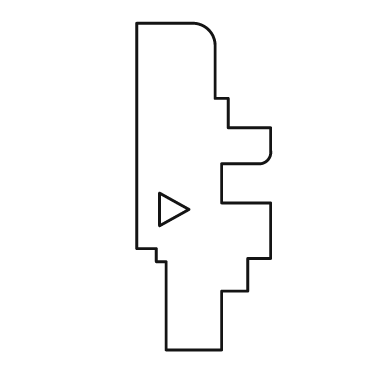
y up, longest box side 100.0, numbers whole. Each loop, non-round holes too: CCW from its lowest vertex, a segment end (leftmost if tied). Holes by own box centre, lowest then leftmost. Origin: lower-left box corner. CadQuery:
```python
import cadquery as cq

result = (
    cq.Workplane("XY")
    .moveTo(9.0, 0.0)
    .lineTo(26.0, 0.0)
    .lineTo(26.0, 18.0)
    .lineTo(34.0, 18.0)
    .lineTo(34.0, 28.0)
    .lineTo(41.0, 28.0)
    .lineTo(41.0, 45.0)
    .lineTo(26.0, 45.0)
    .lineTo(26.0, 57.0)
    .lineTo(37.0, 57.0)
    .threePointArc((40.0, 58.0), (41.0, 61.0))
    .lineTo(41.0, 68.0)
    .lineTo(28.0, 68.0)
    .lineTo(28.0, 77.0)
    .lineTo(24.0, 77.0)
    .lineTo(24.0, 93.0)
    .threePointArc((22.0, 98.0), (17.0, 100.0))
    .lineTo(0.0, 100.0)
    .lineTo(0.0, 31.0)
    .lineTo(6.0, 31.0)
    .lineTo(6.0, 27.0)
    .lineTo(9.0, 27.0)
    .close()
    .moveTo(7.0, 38.0)
    .lineTo(16.0, 43.0)
    .lineTo(7.0, 48.0)
    .close()
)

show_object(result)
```